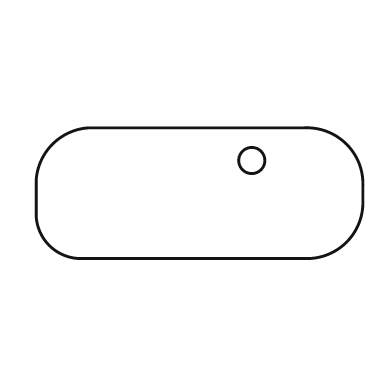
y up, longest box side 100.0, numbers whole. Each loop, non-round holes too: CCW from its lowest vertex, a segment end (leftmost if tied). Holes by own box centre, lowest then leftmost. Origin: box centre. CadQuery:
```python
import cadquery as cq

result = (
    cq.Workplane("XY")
    .moveTo(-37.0, -20.0)
    .lineTo(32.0, -20.0)
    .threePointArc((45.0, -15.0), (50.0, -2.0))
    .lineTo(50.0, 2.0)
    .threePointArc((45.0, 15.0), (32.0, 20.0))
    .lineTo(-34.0, 20.0)
    .threePointArc((-45.0, 15.0), (-50.0, 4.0))
    .lineTo(-50.0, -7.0)
    .threePointArc((-46.0, -16.0), (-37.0, -20.0))
    .close()
    .moveTo(16.0, 10.0)
    .circle(4.0)
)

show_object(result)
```